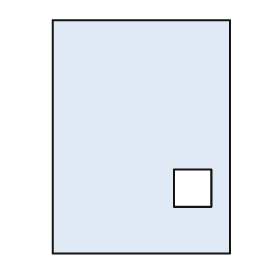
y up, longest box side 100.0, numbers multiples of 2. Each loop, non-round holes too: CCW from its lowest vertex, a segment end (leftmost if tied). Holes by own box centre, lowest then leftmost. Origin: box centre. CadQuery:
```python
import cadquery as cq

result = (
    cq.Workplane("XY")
    .moveTo(-38.0, -50.0)
    .lineTo(38.0, -50.0)
    .lineTo(38.0, 50.0)
    .lineTo(-38.0, 50.0)
    .close()
    .moveTo(14.0, -30.0)
    .lineTo(30.0, -30.0)
    .lineTo(30.0, -14.0)
    .lineTo(14.0, -14.0)
    .close()
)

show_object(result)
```